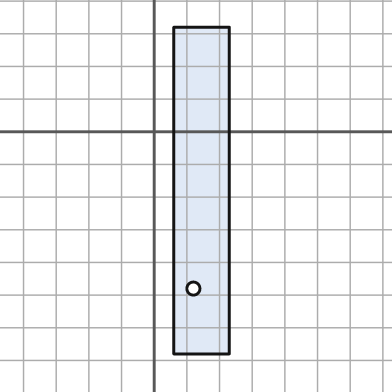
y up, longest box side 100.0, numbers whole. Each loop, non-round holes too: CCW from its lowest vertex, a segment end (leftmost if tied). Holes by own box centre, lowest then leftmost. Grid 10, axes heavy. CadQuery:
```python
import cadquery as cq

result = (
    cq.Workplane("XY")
    .moveTo(6.0, -68.0)
    .lineTo(23.0, -68.0)
    .lineTo(23.0, 32.0)
    .lineTo(6.0, 32.0)
    .close()
    .moveTo(12.0, -48.0)
    .circle(2.0)
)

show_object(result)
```